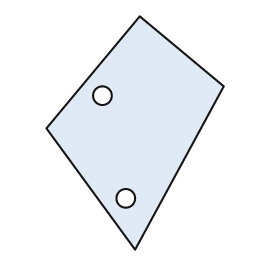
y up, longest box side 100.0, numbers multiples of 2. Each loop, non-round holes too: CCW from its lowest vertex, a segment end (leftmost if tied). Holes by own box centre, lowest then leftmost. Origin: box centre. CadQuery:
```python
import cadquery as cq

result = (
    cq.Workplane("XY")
    .moveTo(0.0, -50.0)
    .lineTo(38.0, 20.0)
    .lineTo(2.0, 50.0)
    .lineTo(-38.0, 2.0)
    .close()
    .moveTo(-4.0, -28.0)
    .circle(4.0)
    .moveTo(-14.0, 16.0)
    .circle(4.0)
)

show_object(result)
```